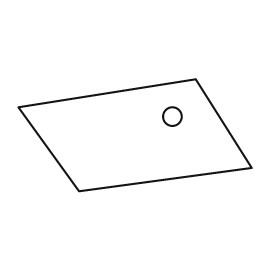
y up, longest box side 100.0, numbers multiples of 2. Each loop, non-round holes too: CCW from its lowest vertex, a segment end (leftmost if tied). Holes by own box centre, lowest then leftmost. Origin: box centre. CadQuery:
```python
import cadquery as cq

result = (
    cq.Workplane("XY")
    .moveTo(-24.0, -24.0)
    .lineTo(50.0, -14.0)
    .lineTo(26.0, 24.0)
    .lineTo(-50.0, 12.0)
    .close()
    .moveTo(16.0, 8.0)
    .circle(4.0)
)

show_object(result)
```